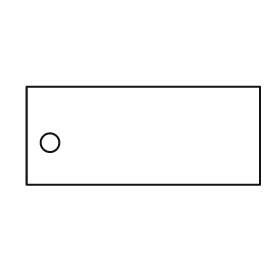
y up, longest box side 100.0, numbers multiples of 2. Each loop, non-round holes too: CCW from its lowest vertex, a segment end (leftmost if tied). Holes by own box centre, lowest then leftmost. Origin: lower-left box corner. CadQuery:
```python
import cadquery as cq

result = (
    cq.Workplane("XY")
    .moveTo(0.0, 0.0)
    .lineTo(100.0, 0.0)
    .lineTo(100.0, 42.0)
    .lineTo(0.0, 42.0)
    .close()
    .moveTo(10.0, 18.0)
    .circle(4.0)
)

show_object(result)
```